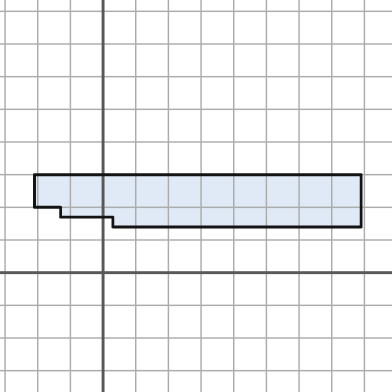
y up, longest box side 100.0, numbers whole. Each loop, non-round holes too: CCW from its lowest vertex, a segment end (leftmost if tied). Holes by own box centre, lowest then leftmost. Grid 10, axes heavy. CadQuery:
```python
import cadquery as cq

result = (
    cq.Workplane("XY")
    .moveTo(3.0, 14.0)
    .lineTo(79.0, 14.0)
    .lineTo(79.0, 30.0)
    .lineTo(-21.0, 30.0)
    .lineTo(-21.0, 20.0)
    .lineTo(-13.0, 20.0)
    .lineTo(-13.0, 17.0)
    .lineTo(3.0, 17.0)
    .close()
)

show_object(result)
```